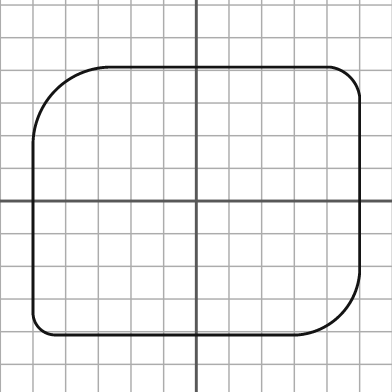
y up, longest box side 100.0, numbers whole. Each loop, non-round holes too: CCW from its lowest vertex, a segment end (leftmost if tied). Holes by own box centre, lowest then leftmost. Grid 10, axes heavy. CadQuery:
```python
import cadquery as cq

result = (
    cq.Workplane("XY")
    .moveTo(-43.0, -41.0)
    .lineTo(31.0, -41.0)
    .threePointArc((44.0, -35.0), (50.0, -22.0))
    .lineTo(50.0, 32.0)
    .threePointArc((47.0, 38.0), (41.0, 41.0))
    .lineTo(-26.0, 41.0)
    .threePointArc((-43.0, 34.0), (-50.0, 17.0))
    .lineTo(-50.0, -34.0)
    .threePointArc((-48.0, -39.0), (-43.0, -41.0))
    .close()
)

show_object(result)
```